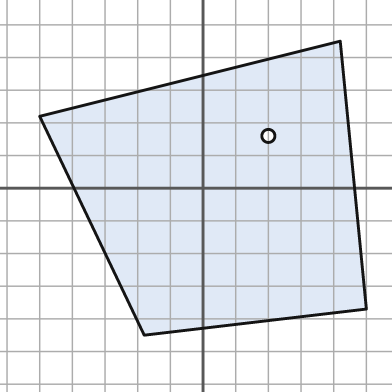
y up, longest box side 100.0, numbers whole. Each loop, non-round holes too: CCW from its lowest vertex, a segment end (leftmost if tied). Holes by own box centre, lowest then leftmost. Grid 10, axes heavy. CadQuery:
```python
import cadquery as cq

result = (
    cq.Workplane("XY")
    .moveTo(-18.0, -45.0)
    .lineTo(50.0, -37.0)
    .lineTo(42.0, 45.0)
    .lineTo(-50.0, 22.0)
    .close()
    .moveTo(20.0, 16.0)
    .circle(2.0)
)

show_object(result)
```